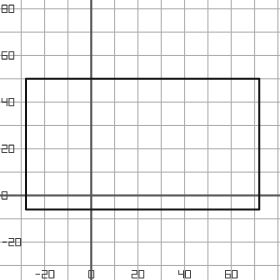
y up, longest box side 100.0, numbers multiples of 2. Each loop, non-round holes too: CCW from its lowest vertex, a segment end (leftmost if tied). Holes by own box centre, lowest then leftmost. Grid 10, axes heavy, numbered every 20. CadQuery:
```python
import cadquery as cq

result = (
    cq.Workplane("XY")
    .moveTo(-28.0, -6.0)
    .lineTo(72.0, -6.0)
    .lineTo(72.0, 50.0)
    .lineTo(-28.0, 50.0)
    .close()
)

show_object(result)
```